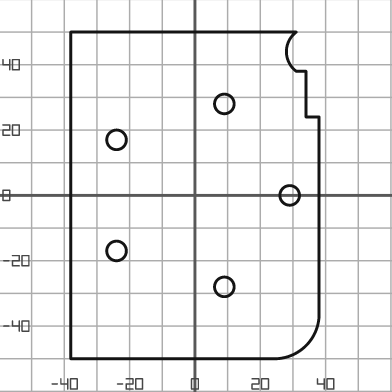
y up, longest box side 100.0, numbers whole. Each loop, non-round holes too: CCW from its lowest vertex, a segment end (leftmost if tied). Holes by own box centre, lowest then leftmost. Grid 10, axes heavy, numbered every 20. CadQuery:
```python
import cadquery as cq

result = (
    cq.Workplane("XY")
    .moveTo(-38.0, -50.0)
    .lineTo(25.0, -50.0)
    .threePointArc((34.0, -46.0), (38.0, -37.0))
    .lineTo(38.0, 24.0)
    .lineTo(34.0, 24.0)
    .lineTo(34.0, 38.0)
    .lineTo(31.0, 38.0)
    .threePointArc((28.0, 44.0), (31.0, 50.0))
    .lineTo(-38.0, 50.0)
    .close()
    .moveTo(9.0, -28.0)
    .circle(3.0)
    .moveTo(-24.0, -17.0)
    .circle(3.0)
    .moveTo(29.0, 0.0)
    .circle(3.0)
    .moveTo(-24.0, 17.0)
    .circle(3.0)
    .moveTo(9.0, 28.0)
    .circle(3.0)
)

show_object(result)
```